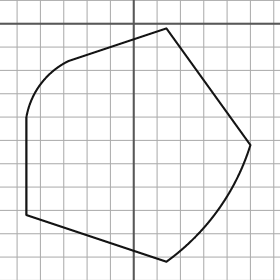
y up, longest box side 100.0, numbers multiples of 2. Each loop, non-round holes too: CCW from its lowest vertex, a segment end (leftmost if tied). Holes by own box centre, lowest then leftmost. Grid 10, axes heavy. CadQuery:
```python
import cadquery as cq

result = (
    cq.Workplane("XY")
    .moveTo(14.0, -102.0)
    .threePointArc((36.0, -80.0), (50.0, -52.0))
    .lineTo(14.0, -2.0)
    .lineTo(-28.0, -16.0)
    .threePointArc((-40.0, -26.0), (-46.0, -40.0))
    .lineTo(-46.0, -82.0)
    .close()
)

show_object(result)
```